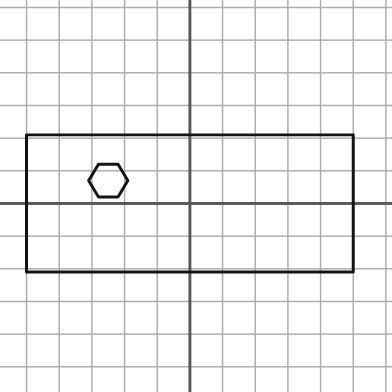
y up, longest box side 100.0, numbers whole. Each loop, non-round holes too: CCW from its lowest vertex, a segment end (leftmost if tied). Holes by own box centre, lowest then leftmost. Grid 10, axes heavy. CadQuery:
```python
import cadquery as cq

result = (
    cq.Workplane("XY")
    .moveTo(-50.0, -21.0)
    .lineTo(50.0, -21.0)
    .lineTo(50.0, 21.0)
    .lineTo(-50.0, 21.0)
    .close()
    .moveTo(-28.0, 2.0)
    .lineTo(-22.0, 2.0)
    .lineTo(-19.0, 7.0)
    .lineTo(-22.0, 12.0)
    .lineTo(-28.0, 12.0)
    .lineTo(-31.0, 7.0)
    .close()
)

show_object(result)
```